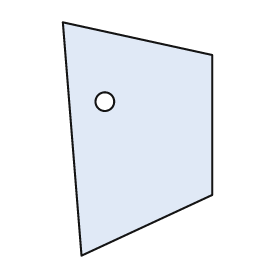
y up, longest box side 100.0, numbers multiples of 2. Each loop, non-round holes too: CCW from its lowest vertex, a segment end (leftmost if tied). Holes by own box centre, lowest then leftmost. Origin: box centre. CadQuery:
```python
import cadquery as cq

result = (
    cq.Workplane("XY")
    .moveTo(-24.0, -50.0)
    .lineTo(32.0, -24.0)
    .lineTo(32.0, 36.0)
    .lineTo(-32.0, 50.0)
    .close()
    .moveTo(-14.0, 16.0)
    .circle(4.0)
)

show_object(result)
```